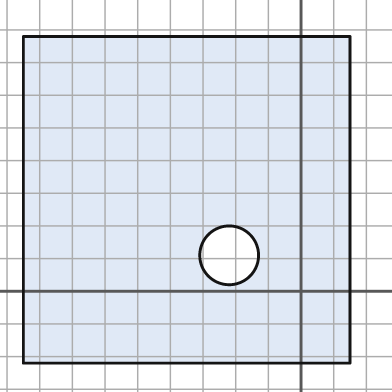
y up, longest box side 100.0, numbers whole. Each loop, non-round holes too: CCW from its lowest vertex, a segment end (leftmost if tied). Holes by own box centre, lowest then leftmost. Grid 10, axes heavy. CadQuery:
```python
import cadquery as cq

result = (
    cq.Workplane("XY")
    .moveTo(-85.0, -22.0)
    .lineTo(15.0, -22.0)
    .lineTo(15.0, 78.0)
    .lineTo(-85.0, 78.0)
    .close()
    .moveTo(-22.0, 11.0)
    .circle(9.0)
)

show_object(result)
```